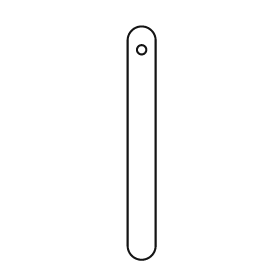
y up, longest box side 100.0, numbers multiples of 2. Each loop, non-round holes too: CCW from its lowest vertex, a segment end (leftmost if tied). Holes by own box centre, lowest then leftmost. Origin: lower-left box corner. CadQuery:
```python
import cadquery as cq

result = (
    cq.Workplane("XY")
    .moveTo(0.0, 6.0)
    .threePointArc((6.0, 0.0), (12.0, 6.0))
    .lineTo(12.0, 94.0)
    .threePointArc((6.0, 100.0), (0.0, 94.0))
    .close()
    .moveTo(6.0, 90.0)
    .circle(2.0)
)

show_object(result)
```